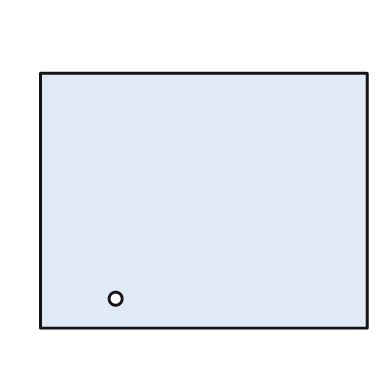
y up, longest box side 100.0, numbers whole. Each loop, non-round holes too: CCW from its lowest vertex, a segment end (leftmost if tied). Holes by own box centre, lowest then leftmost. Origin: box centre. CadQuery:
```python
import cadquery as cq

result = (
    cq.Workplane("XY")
    .moveTo(-50.0, -39.0)
    .lineTo(50.0, -39.0)
    .lineTo(50.0, 39.0)
    .lineTo(-50.0, 39.0)
    .close()
    .moveTo(-27.0, -30.0)
    .circle(2.0)
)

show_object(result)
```